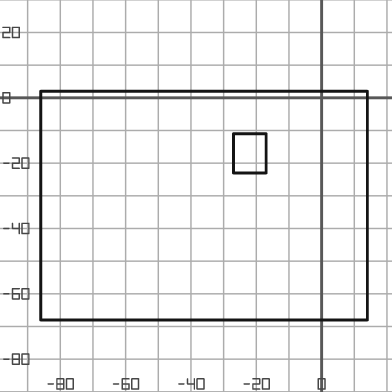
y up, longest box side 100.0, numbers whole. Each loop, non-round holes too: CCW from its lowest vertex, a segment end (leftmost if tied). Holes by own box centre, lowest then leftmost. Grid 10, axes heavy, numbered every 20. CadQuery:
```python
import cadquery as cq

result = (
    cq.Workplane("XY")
    .moveTo(-86.0, -68.0)
    .lineTo(14.0, -68.0)
    .lineTo(14.0, 2.0)
    .lineTo(-86.0, 2.0)
    .close()
    .moveTo(-27.0, -23.0)
    .lineTo(-17.0, -23.0)
    .lineTo(-17.0, -11.0)
    .lineTo(-27.0, -11.0)
    .close()
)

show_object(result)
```